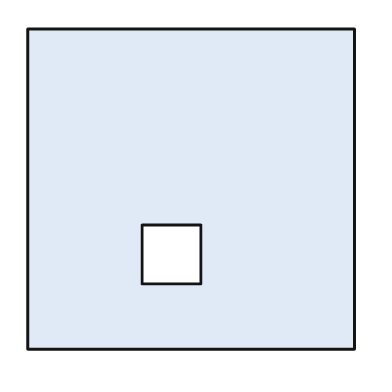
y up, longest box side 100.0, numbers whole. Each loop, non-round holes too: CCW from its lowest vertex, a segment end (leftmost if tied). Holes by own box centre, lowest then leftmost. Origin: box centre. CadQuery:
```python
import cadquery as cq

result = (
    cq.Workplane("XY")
    .moveTo(-50.0, -49.0)
    .lineTo(50.0, -49.0)
    .lineTo(50.0, 49.0)
    .lineTo(-50.0, 49.0)
    .close()
    .moveTo(-15.0, -29.0)
    .lineTo(3.0, -29.0)
    .lineTo(3.0, -11.0)
    .lineTo(-15.0, -11.0)
    .close()
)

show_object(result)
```